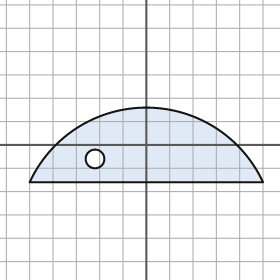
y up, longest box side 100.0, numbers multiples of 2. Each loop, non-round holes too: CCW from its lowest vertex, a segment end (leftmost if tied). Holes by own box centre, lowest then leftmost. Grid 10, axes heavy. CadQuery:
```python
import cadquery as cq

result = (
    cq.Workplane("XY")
    .moveTo(-50.0, -16.0)
    .lineTo(50.0, -16.0)
    .threePointArc((0.0, 16.0), (-50.0, -16.0))
    .close()
    .moveTo(-22.0, -6.0)
    .circle(4.0)
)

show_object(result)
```